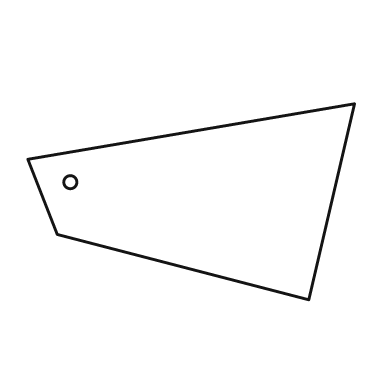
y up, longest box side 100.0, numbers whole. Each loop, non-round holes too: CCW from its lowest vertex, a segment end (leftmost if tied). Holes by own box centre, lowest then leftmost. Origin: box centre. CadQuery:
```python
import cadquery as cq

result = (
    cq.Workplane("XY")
    .moveTo(36.0, -30.0)
    .lineTo(50.0, 30.0)
    .lineTo(-50.0, 13.0)
    .lineTo(-41.0, -10.0)
    .close()
    .moveTo(-37.0, 6.0)
    .circle(2.0)
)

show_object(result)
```